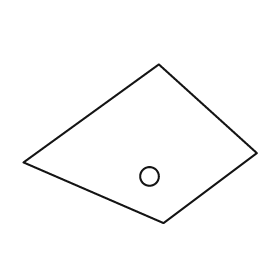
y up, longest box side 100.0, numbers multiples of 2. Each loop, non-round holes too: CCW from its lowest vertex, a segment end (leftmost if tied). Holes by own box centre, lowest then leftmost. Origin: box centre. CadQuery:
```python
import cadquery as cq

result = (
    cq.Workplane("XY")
    .moveTo(10.0, -34.0)
    .lineTo(50.0, -4.0)
    .lineTo(8.0, 34.0)
    .lineTo(-50.0, -8.0)
    .close()
    .moveTo(4.0, -14.0)
    .circle(4.0)
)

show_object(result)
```